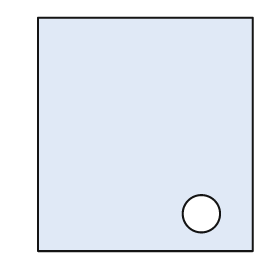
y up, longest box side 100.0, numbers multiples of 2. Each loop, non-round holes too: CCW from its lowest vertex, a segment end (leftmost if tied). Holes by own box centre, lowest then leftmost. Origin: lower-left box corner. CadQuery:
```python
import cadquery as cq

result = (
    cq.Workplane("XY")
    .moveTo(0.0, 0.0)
    .lineTo(92.0, 0.0)
    .lineTo(92.0, 100.0)
    .lineTo(0.0, 100.0)
    .close()
    .moveTo(70.0, 16.0)
    .circle(8.0)
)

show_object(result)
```